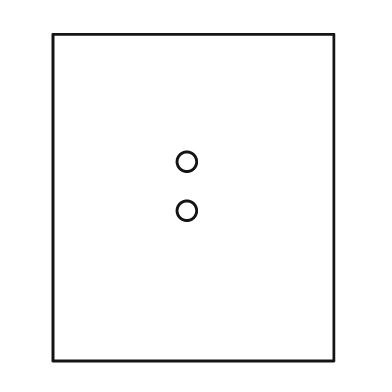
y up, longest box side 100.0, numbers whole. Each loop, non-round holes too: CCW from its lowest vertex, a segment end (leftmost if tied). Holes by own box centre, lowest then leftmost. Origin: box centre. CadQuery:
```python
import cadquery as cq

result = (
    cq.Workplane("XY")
    .moveTo(-43.0, -50.0)
    .lineTo(43.0, -50.0)
    .lineTo(43.0, 50.0)
    .lineTo(-43.0, 50.0)
    .close()
    .moveTo(-2.0, -4.0)
    .circle(3.0)
    .moveTo(-2.0, 11.0)
    .circle(3.0)
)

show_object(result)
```